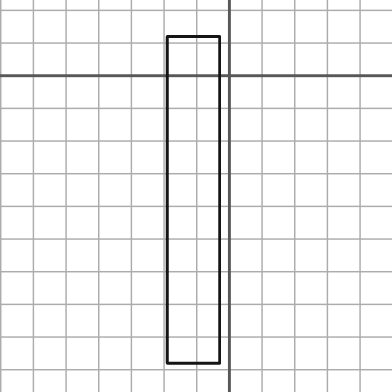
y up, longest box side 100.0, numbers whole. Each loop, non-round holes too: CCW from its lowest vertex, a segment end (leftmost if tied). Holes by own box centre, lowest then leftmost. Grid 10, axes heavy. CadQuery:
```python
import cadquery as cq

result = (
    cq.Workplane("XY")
    .moveTo(-19.0, -88.0)
    .lineTo(-3.0, -88.0)
    .lineTo(-3.0, 12.0)
    .lineTo(-19.0, 12.0)
    .close()
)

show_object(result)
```